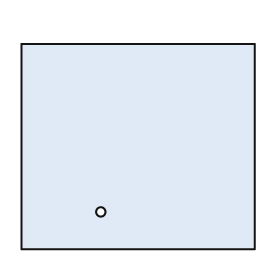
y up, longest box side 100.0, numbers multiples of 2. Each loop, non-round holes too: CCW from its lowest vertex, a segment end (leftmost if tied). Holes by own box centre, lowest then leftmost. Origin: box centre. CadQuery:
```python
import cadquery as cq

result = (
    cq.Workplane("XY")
    .moveTo(-50.0, -44.0)
    .lineTo(50.0, -44.0)
    .lineTo(50.0, 44.0)
    .lineTo(-50.0, 44.0)
    .close()
    .moveTo(-16.0, -28.0)
    .circle(2.0)
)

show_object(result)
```